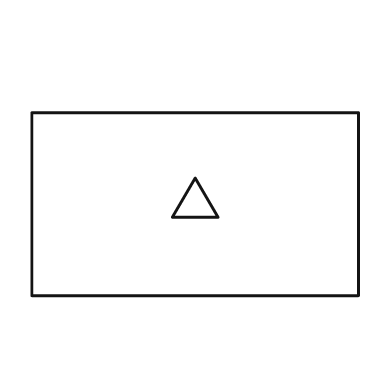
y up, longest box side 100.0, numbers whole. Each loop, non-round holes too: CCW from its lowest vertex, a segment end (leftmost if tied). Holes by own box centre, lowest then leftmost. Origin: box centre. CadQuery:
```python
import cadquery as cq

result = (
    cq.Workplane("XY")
    .moveTo(-50.0, -28.0)
    .lineTo(50.0, -28.0)
    .lineTo(50.0, 28.0)
    .lineTo(-50.0, 28.0)
    .close()
    .moveTo(-7.0, -4.0)
    .lineTo(7.0, -4.0)
    .lineTo(0.0, 8.0)
    .close()
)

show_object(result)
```